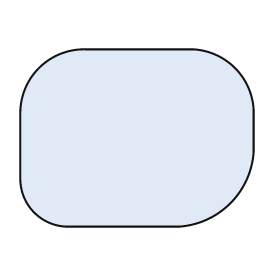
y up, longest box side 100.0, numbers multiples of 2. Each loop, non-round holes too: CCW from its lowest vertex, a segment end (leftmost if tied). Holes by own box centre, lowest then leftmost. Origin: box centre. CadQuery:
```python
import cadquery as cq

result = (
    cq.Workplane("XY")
    .moveTo(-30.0, -38.0)
    .lineTo(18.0, -38.0)
    .threePointArc((40.0, -28.0), (50.0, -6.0))
    .lineTo(50.0, 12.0)
    .threePointArc((42.0, 30.0), (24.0, 38.0))
    .lineTo(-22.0, 38.0)
    .threePointArc((-42.0, 30.0), (-50.0, 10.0))
    .lineTo(-50.0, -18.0)
    .threePointArc((-44.0, -32.0), (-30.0, -38.0))
    .close()
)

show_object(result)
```